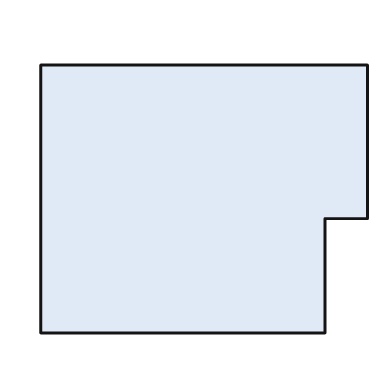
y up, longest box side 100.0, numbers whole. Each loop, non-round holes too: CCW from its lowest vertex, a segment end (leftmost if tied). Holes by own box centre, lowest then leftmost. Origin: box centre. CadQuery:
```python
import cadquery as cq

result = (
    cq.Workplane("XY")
    .moveTo(-50.0, -41.0)
    .lineTo(37.0, -41.0)
    .lineTo(37.0, -6.0)
    .lineTo(50.0, -6.0)
    .lineTo(50.0, 41.0)
    .lineTo(-50.0, 41.0)
    .close()
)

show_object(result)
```